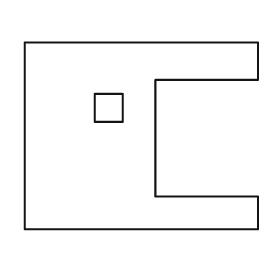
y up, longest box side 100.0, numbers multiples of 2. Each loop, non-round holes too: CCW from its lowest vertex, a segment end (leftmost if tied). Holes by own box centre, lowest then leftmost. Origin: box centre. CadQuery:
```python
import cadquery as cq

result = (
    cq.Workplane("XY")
    .moveTo(-50.0, -40.0)
    .lineTo(50.0, -40.0)
    .lineTo(50.0, -26.0)
    .lineTo(6.0, -26.0)
    .lineTo(6.0, 24.0)
    .lineTo(50.0, 24.0)
    .lineTo(50.0, 40.0)
    .lineTo(-50.0, 40.0)
    .close()
    .moveTo(-20.0, 6.0)
    .lineTo(-8.0, 6.0)
    .lineTo(-8.0, 18.0)
    .lineTo(-20.0, 18.0)
    .close()
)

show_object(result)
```